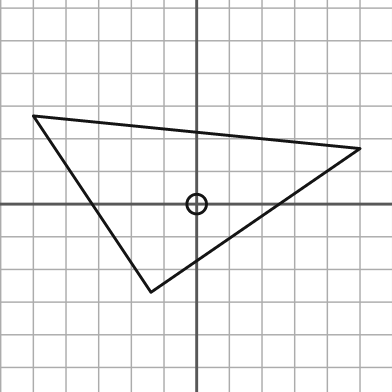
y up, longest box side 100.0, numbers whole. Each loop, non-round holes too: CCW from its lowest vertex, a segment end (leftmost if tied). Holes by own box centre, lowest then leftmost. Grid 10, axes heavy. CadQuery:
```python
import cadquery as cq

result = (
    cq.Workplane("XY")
    .moveTo(-14.0, -27.0)
    .lineTo(50.0, 17.0)
    .lineTo(-50.0, 27.0)
    .close()
    .moveTo(0.0, 0.0)
    .circle(3.0)
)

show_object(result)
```